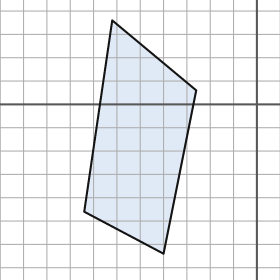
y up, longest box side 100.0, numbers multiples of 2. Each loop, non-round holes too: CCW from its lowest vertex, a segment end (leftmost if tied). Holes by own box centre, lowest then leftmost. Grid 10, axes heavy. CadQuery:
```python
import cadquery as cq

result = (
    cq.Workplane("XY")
    .moveTo(-40.0, -64.0)
    .lineTo(-26.0, 6.0)
    .lineTo(-62.0, 36.0)
    .lineTo(-74.0, -46.0)
    .close()
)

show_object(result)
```